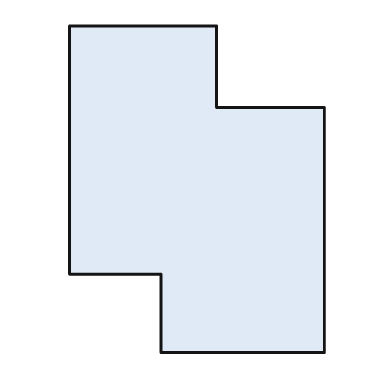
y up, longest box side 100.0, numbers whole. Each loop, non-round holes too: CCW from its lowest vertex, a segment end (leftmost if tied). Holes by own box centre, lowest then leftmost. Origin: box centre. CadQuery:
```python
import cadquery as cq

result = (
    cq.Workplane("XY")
    .moveTo(-11.0, -50.0)
    .lineTo(39.0, -50.0)
    .lineTo(39.0, 25.0)
    .lineTo(6.0, 25.0)
    .lineTo(6.0, 50.0)
    .lineTo(-39.0, 50.0)
    .lineTo(-39.0, -26.0)
    .lineTo(-11.0, -26.0)
    .close()
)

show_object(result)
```